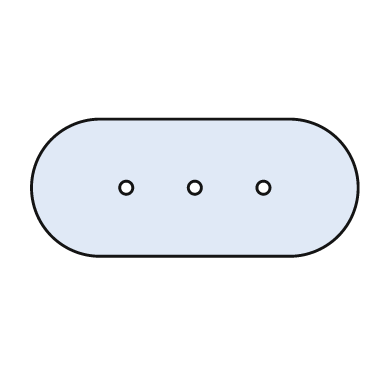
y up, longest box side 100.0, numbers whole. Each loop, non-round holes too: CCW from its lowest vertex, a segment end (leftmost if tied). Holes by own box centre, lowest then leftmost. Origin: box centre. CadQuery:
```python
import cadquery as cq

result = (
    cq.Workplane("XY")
    .moveTo(-29.0, -21.0)
    .lineTo(29.0, -21.0)
    .threePointArc((50.0, 0.0), (29.0, 21.0))
    .lineTo(-29.0, 21.0)
    .threePointArc((-50.0, 0.0), (-29.0, -21.0))
    .close()
    .moveTo(-21.0, 0.0)
    .circle(2.0)
    .moveTo(0.0, 0.0)
    .circle(2.0)
    .moveTo(21.0, 0.0)
    .circle(2.0)
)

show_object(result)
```